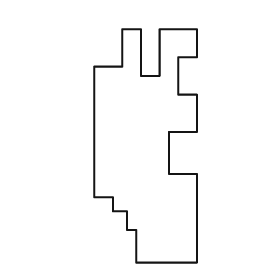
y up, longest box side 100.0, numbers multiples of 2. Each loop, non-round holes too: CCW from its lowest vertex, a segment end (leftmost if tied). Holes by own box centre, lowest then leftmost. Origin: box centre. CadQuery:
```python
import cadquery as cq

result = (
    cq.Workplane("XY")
    .moveTo(-4.0, -50.0)
    .lineTo(22.0, -50.0)
    .lineTo(22.0, -12.0)
    .lineTo(10.0, -12.0)
    .lineTo(10.0, 6.0)
    .lineTo(22.0, 6.0)
    .lineTo(22.0, 22.0)
    .lineTo(14.0, 22.0)
    .lineTo(14.0, 38.0)
    .lineTo(22.0, 38.0)
    .lineTo(22.0, 50.0)
    .lineTo(6.0, 50.0)
    .lineTo(6.0, 30.0)
    .lineTo(-2.0, 30.0)
    .lineTo(-2.0, 50.0)
    .lineTo(-10.0, 50.0)
    .lineTo(-10.0, 34.0)
    .lineTo(-22.0, 34.0)
    .lineTo(-22.0, -22.0)
    .lineTo(-14.0, -22.0)
    .lineTo(-14.0, -28.0)
    .lineTo(-8.0, -28.0)
    .lineTo(-8.0, -36.0)
    .lineTo(-4.0, -36.0)
    .close()
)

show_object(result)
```